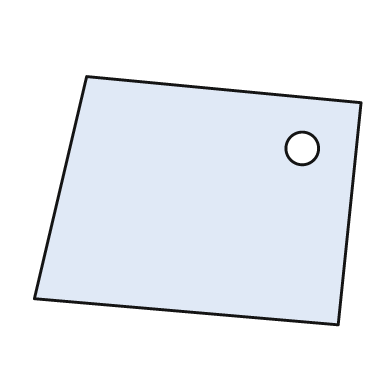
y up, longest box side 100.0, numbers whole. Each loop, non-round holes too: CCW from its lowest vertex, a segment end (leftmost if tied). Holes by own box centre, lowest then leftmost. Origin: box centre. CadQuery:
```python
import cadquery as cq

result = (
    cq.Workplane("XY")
    .moveTo(43.0, -38.0)
    .lineTo(50.0, 30.0)
    .lineTo(-34.0, 38.0)
    .lineTo(-50.0, -30.0)
    .close()
    .moveTo(32.0, 16.0)
    .circle(5.0)
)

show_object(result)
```